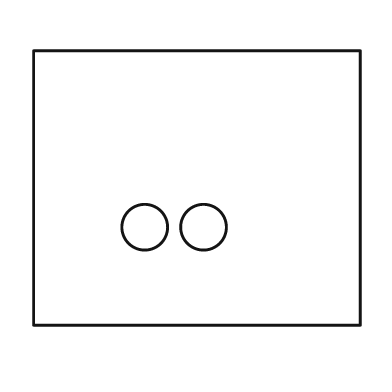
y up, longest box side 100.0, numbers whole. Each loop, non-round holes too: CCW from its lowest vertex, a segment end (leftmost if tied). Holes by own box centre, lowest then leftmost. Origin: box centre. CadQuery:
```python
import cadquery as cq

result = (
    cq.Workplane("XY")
    .moveTo(-50.0, -42.0)
    .lineTo(50.0, -42.0)
    .lineTo(50.0, 42.0)
    .lineTo(-50.0, 42.0)
    .close()
    .moveTo(-16.0, -12.0)
    .circle(7.0)
    .moveTo(2.0, -12.0)
    .circle(7.0)
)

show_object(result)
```